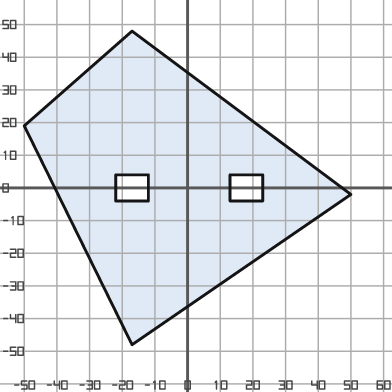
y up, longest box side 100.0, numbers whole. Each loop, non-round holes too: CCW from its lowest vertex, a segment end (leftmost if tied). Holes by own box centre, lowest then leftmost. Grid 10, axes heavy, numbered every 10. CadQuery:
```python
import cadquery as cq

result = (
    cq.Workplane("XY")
    .moveTo(-17.0, -48.0)
    .lineTo(50.0, -2.0)
    .lineTo(-17.0, 48.0)
    .lineTo(-50.0, 19.0)
    .close()
    .moveTo(-22.0, -4.0)
    .lineTo(-12.0, -4.0)
    .lineTo(-12.0, 4.0)
    .lineTo(-22.0, 4.0)
    .close()
    .moveTo(13.0, -4.0)
    .lineTo(23.0, -4.0)
    .lineTo(23.0, 4.0)
    .lineTo(13.0, 4.0)
    .close()
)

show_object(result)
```